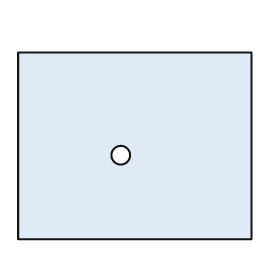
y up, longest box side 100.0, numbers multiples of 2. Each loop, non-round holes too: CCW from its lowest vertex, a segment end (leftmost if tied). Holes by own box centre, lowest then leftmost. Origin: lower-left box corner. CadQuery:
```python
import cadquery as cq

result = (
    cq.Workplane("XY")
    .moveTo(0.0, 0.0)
    .lineTo(100.0, 0.0)
    .lineTo(100.0, 80.0)
    .lineTo(0.0, 80.0)
    .close()
    .moveTo(44.0, 36.0)
    .circle(4.0)
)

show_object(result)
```